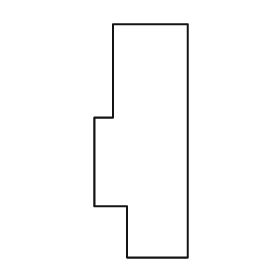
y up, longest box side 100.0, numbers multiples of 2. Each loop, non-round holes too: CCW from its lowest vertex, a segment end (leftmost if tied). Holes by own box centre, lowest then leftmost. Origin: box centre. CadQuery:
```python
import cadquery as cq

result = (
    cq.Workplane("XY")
    .moveTo(-6.0, -50.0)
    .lineTo(20.0, -50.0)
    .lineTo(20.0, 50.0)
    .lineTo(-12.0, 50.0)
    .lineTo(-12.0, 10.0)
    .lineTo(-20.0, 10.0)
    .lineTo(-20.0, -28.0)
    .lineTo(-6.0, -28.0)
    .close()
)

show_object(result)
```